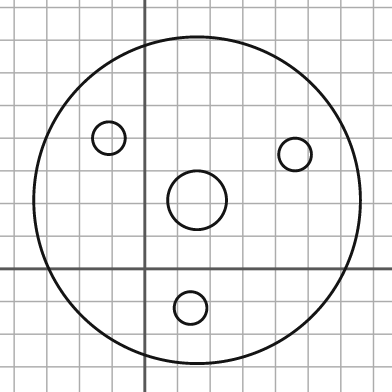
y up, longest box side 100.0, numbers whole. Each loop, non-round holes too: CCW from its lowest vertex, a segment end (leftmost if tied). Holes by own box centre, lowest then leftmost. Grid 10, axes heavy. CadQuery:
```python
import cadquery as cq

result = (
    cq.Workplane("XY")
    .moveTo(16.0, 21.0)
    .circle(50.0)
    .moveTo(14.0, -12.0)
    .circle(5.0)
    .moveTo(16.0, 21.0)
    .circle(9.0)
    .moveTo(46.0, 35.0)
    .circle(5.0)
    .moveTo(-11.0, 40.0)
    .circle(5.0)
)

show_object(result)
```